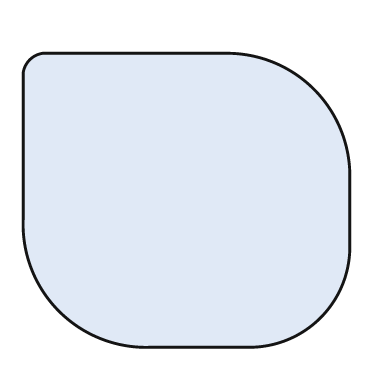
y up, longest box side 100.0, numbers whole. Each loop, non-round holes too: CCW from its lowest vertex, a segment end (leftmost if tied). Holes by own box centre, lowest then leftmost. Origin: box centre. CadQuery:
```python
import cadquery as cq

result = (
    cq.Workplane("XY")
    .moveTo(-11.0, -45.0)
    .lineTo(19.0, -45.0)
    .threePointArc((41.0, -36.0), (50.0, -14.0))
    .lineTo(50.0, 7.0)
    .threePointArc((39.0, 34.0), (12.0, 45.0))
    .lineTo(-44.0, 45.0)
    .threePointArc((-48.0, 43.0), (-50.0, 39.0))
    .lineTo(-50.0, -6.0)
    .threePointArc((-39.0, -34.0), (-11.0, -45.0))
    .close()
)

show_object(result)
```